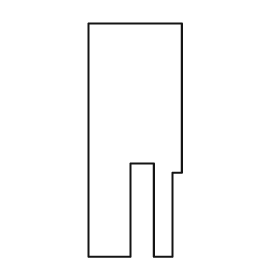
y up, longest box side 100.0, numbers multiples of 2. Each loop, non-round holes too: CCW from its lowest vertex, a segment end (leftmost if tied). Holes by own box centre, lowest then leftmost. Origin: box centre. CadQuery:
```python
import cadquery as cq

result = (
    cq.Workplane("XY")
    .moveTo(-20.0, -50.0)
    .lineTo(-2.0, -50.0)
    .lineTo(-2.0, -10.0)
    .lineTo(8.0, -10.0)
    .lineTo(8.0, -50.0)
    .lineTo(16.0, -50.0)
    .lineTo(16.0, -14.0)
    .lineTo(20.0, -14.0)
    .lineTo(20.0, 50.0)
    .lineTo(-20.0, 50.0)
    .close()
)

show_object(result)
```